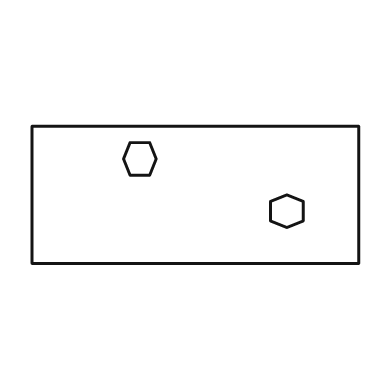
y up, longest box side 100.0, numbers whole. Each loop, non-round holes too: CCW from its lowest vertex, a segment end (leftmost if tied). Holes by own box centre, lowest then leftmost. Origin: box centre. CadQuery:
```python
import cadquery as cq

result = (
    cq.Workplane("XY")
    .moveTo(-50.0, -21.0)
    .lineTo(50.0, -21.0)
    .lineTo(50.0, 21.0)
    .lineTo(-50.0, 21.0)
    .close()
    .moveTo(28.0, -10.0)
    .lineTo(33.0, -8.0)
    .lineTo(33.0, -2.0)
    .lineTo(28.0, 0.0)
    .lineTo(23.0, -2.0)
    .lineTo(23.0, -8.0)
    .close()
    .moveTo(-20.0, 6.0)
    .lineTo(-14.0, 6.0)
    .lineTo(-12.0, 11.0)
    .lineTo(-14.0, 16.0)
    .lineTo(-20.0, 16.0)
    .lineTo(-22.0, 11.0)
    .close()
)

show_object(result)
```